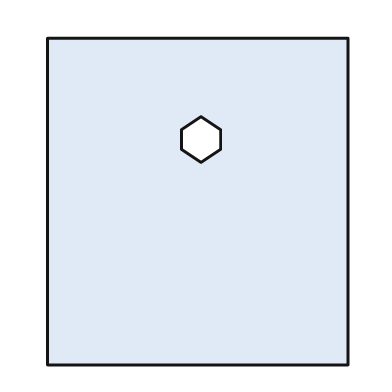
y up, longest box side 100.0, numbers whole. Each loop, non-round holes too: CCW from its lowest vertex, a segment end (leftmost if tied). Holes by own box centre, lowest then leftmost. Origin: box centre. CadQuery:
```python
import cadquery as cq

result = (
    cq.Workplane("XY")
    .moveTo(-46.0, -50.0)
    .lineTo(46.0, -50.0)
    .lineTo(46.0, 50.0)
    .lineTo(-46.0, 50.0)
    .close()
    .moveTo(1.0, 12.0)
    .lineTo(7.0, 16.0)
    .lineTo(7.0, 22.0)
    .lineTo(1.0, 26.0)
    .lineTo(-5.0, 22.0)
    .lineTo(-5.0, 16.0)
    .close()
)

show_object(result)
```